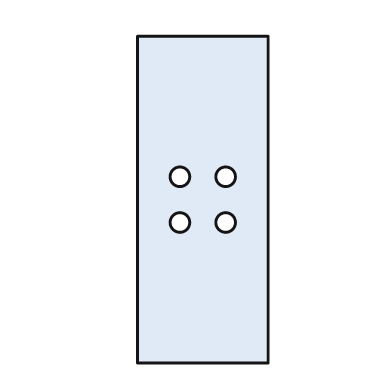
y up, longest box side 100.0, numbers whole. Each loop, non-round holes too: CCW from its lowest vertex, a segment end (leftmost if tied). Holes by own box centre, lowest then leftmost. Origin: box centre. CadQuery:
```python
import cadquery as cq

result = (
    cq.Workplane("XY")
    .moveTo(-20.0, -50.0)
    .lineTo(20.0, -50.0)
    .lineTo(20.0, 50.0)
    .lineTo(-20.0, 50.0)
    .close()
    .moveTo(-7.0, -7.0)
    .circle(3.0)
    .moveTo(7.0, -7.0)
    .circle(3.0)
    .moveTo(-7.0, 7.0)
    .circle(3.0)
    .moveTo(7.0, 7.0)
    .circle(3.0)
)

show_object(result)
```